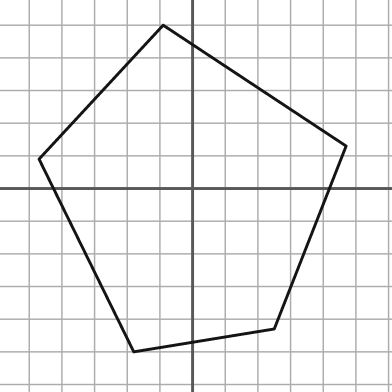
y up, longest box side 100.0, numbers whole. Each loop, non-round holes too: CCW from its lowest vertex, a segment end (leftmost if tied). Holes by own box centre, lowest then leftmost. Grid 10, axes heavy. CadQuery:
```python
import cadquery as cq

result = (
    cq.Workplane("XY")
    .moveTo(-18.0, -50.0)
    .lineTo(25.0, -43.0)
    .lineTo(47.0, 13.0)
    .lineTo(-9.0, 50.0)
    .lineTo(-47.0, 9.0)
    .close()
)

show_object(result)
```